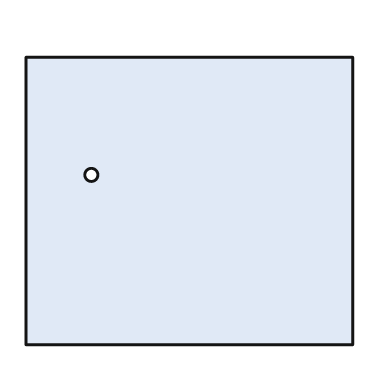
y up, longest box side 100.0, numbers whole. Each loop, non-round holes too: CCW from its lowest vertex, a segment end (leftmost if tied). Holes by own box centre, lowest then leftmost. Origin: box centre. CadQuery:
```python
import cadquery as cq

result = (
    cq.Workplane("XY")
    .moveTo(-50.0, -44.0)
    .lineTo(50.0, -44.0)
    .lineTo(50.0, 44.0)
    .lineTo(-50.0, 44.0)
    .close()
    .moveTo(-30.0, 8.0)
    .circle(2.0)
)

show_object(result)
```